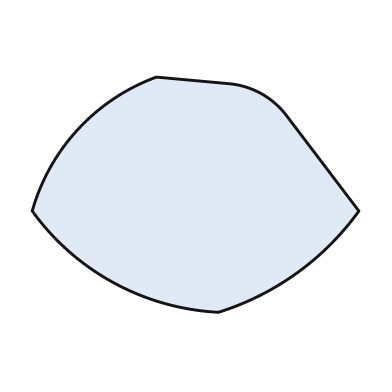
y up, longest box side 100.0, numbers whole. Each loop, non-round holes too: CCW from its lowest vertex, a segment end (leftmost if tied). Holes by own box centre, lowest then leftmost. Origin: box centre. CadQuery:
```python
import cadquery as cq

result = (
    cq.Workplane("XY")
    .moveTo(7.0, -36.0)
    .threePointArc((31.0, -24.0), (50.0, -5.0))
    .lineTo(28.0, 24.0)
    .threePointArc((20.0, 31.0), (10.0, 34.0))
    .lineTo(-12.0, 36.0)
    .threePointArc((-36.0, 20.0), (-50.0, -5.0))
    .threePointArc((-25.0, -27.0), (7.0, -36.0))
    .close()
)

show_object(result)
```